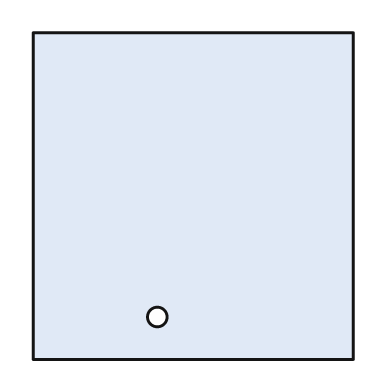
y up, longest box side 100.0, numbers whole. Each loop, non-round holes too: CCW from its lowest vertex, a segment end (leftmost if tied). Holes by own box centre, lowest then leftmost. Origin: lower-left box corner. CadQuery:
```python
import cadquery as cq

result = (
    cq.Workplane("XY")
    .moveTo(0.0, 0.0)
    .lineTo(98.0, 0.0)
    .lineTo(98.0, 100.0)
    .lineTo(0.0, 100.0)
    .close()
    .moveTo(38.0, 13.0)
    .circle(3.0)
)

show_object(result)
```